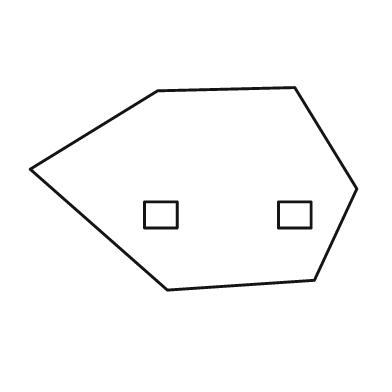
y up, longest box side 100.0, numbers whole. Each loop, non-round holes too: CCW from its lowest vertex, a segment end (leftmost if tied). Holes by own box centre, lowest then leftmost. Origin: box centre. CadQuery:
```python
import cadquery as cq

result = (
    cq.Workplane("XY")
    .moveTo(-8.0, -31.0)
    .lineTo(37.0, -28.0)
    .lineTo(50.0, 0.0)
    .lineTo(31.0, 31.0)
    .lineTo(-11.0, 30.0)
    .lineTo(-50.0, 6.0)
    .close()
    .moveTo(-15.0, -12.0)
    .lineTo(-5.0, -12.0)
    .lineTo(-5.0, -4.0)
    .lineTo(-15.0, -4.0)
    .close()
    .moveTo(26.0, -12.0)
    .lineTo(36.0, -12.0)
    .lineTo(36.0, -4.0)
    .lineTo(26.0, -4.0)
    .close()
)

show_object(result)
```